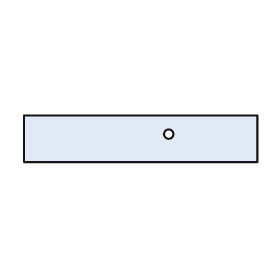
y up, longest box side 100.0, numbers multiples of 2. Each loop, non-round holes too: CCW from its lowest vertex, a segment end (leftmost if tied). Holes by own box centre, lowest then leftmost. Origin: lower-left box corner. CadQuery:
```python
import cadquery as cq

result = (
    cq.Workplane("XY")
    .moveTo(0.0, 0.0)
    .lineTo(100.0, 0.0)
    .lineTo(100.0, 20.0)
    .lineTo(0.0, 20.0)
    .close()
    .moveTo(62.0, 12.0)
    .circle(2.0)
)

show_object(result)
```